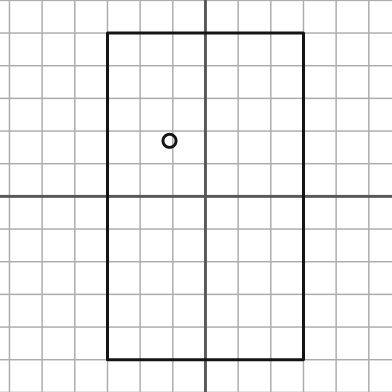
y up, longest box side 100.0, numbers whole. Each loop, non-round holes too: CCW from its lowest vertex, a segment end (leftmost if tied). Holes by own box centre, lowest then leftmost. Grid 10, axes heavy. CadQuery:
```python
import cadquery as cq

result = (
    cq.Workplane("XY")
    .moveTo(-30.0, -50.0)
    .lineTo(30.0, -50.0)
    .lineTo(30.0, 50.0)
    .lineTo(-30.0, 50.0)
    .close()
    .moveTo(-11.0, 17.0)
    .circle(2.0)
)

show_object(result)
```